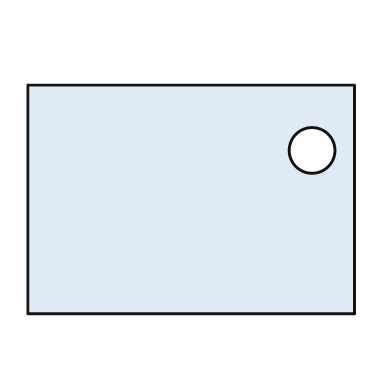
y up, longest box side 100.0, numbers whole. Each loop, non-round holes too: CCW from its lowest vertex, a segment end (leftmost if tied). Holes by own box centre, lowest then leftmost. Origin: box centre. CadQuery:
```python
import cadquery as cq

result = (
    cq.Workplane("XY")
    .moveTo(-50.0, -35.0)
    .lineTo(50.0, -35.0)
    .lineTo(50.0, 35.0)
    .lineTo(-50.0, 35.0)
    .close()
    .moveTo(37.0, 15.0)
    .circle(7.0)
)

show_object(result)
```